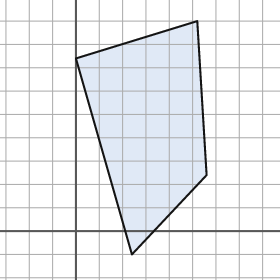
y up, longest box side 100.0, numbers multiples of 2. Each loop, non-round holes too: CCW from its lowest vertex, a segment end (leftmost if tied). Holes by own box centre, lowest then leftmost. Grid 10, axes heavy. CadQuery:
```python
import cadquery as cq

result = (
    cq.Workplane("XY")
    .moveTo(24.0, -10.0)
    .lineTo(56.0, 24.0)
    .lineTo(52.0, 90.0)
    .lineTo(0.0, 74.0)
    .close()
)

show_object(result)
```